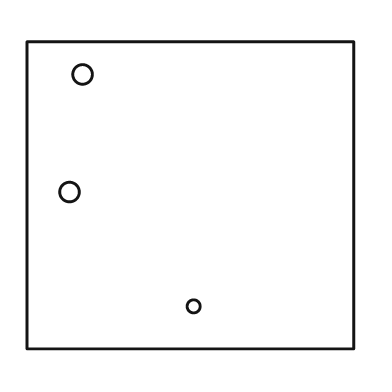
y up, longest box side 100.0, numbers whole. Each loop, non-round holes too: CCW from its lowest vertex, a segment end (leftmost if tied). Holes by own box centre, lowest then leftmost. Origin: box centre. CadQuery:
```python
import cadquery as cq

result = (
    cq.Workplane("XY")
    .moveTo(-50.0, -47.0)
    .lineTo(50.0, -47.0)
    .lineTo(50.0, 47.0)
    .lineTo(-50.0, 47.0)
    .close()
    .moveTo(1.0, -34.0)
    .circle(2.0)
    .moveTo(-37.0, 1.0)
    .circle(3.0)
    .moveTo(-33.0, 37.0)
    .circle(3.0)
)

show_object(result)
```